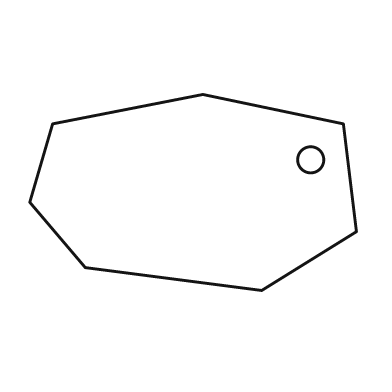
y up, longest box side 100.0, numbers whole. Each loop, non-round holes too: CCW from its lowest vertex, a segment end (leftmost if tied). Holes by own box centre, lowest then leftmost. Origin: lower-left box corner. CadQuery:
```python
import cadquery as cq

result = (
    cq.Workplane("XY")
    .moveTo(71.0, 0.0)
    .lineTo(100.0, 18.0)
    .lineTo(96.0, 51.0)
    .lineTo(53.0, 60.0)
    .lineTo(7.0, 51.0)
    .lineTo(0.0, 27.0)
    .lineTo(17.0, 7.0)
    .close()
    .moveTo(86.0, 40.0)
    .circle(4.0)
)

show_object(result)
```